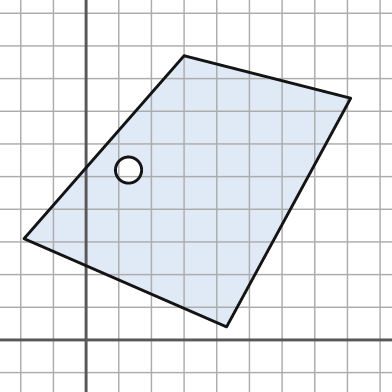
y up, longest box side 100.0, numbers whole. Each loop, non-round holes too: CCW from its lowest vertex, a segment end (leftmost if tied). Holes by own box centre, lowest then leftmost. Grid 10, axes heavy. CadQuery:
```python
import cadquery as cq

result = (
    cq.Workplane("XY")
    .moveTo(43.0, 4.0)
    .lineTo(81.0, 74.0)
    .lineTo(30.0, 87.0)
    .lineTo(-19.0, 31.0)
    .close()
    .moveTo(13.0, 52.0)
    .circle(4.0)
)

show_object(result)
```